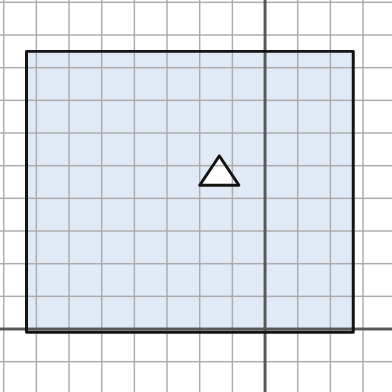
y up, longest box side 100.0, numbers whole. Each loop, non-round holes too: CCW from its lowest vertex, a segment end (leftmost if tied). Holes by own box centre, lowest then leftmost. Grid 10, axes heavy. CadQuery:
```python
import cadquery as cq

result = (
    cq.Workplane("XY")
    .moveTo(-73.0, -1.0)
    .lineTo(27.0, -1.0)
    .lineTo(27.0, 85.0)
    .lineTo(-73.0, 85.0)
    .close()
    .moveTo(-20.0, 44.0)
    .lineTo(-8.0, 44.0)
    .lineTo(-14.0, 53.0)
    .close()
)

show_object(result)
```